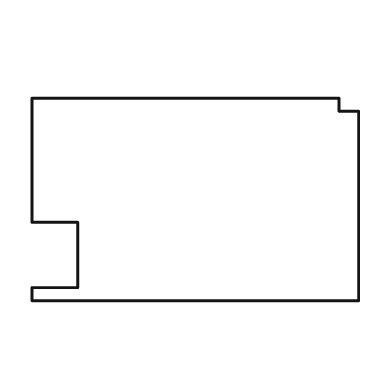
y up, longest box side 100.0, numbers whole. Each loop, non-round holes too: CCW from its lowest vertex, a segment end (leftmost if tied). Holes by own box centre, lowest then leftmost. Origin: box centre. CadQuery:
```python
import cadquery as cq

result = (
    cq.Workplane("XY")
    .moveTo(-50.0, -31.0)
    .lineTo(50.0, -31.0)
    .lineTo(50.0, 27.0)
    .lineTo(44.0, 27.0)
    .lineTo(44.0, 31.0)
    .lineTo(-50.0, 31.0)
    .lineTo(-50.0, -7.0)
    .lineTo(-36.0, -7.0)
    .lineTo(-36.0, -27.0)
    .lineTo(-50.0, -27.0)
    .close()
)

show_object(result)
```